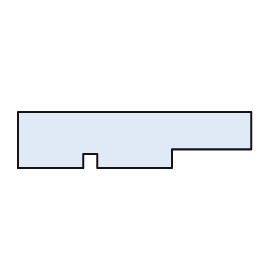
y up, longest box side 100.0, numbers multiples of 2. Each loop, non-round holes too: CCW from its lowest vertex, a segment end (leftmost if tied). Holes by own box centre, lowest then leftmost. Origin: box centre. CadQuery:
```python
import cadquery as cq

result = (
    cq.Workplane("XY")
    .moveTo(-50.0, -12.0)
    .lineTo(-22.0, -12.0)
    .lineTo(-22.0, -6.0)
    .lineTo(-16.0, -6.0)
    .lineTo(-16.0, -12.0)
    .lineTo(16.0, -12.0)
    .lineTo(16.0, -4.0)
    .lineTo(50.0, -4.0)
    .lineTo(50.0, 12.0)
    .lineTo(-50.0, 12.0)
    .close()
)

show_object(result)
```